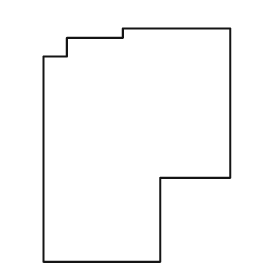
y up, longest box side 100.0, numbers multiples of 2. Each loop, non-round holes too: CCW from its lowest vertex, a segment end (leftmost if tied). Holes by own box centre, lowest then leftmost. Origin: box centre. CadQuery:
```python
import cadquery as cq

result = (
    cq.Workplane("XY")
    .moveTo(-40.0, -50.0)
    .lineTo(10.0, -50.0)
    .lineTo(10.0, -14.0)
    .lineTo(40.0, -14.0)
    .lineTo(40.0, 50.0)
    .lineTo(-6.0, 50.0)
    .lineTo(-6.0, 46.0)
    .lineTo(-30.0, 46.0)
    .lineTo(-30.0, 38.0)
    .lineTo(-40.0, 38.0)
    .close()
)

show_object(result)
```